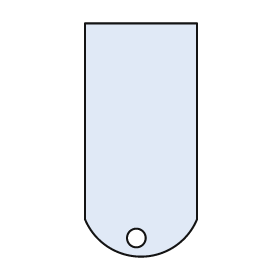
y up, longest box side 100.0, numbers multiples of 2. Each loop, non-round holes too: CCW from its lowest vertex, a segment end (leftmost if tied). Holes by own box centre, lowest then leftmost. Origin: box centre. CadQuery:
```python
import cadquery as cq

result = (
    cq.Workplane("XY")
    .moveTo(-24.0, -34.0)
    .threePointArc((0.0, -50.0), (24.0, -34.0))
    .lineTo(24.0, 50.0)
    .lineTo(-24.0, 50.0)
    .close()
    .moveTo(-2.0, -42.0)
    .circle(4.0)
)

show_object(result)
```